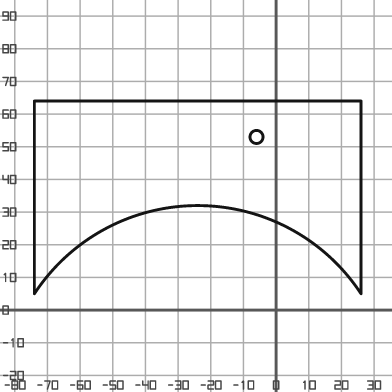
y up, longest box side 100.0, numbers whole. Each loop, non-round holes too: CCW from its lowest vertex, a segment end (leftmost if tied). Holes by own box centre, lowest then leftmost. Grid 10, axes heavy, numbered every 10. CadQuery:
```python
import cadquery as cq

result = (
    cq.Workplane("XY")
    .moveTo(-74.0, 5.0)
    .threePointArc((-24.0, 32.0), (26.0, 5.0))
    .lineTo(26.0, 64.0)
    .lineTo(-74.0, 64.0)
    .close()
    .moveTo(-6.0, 53.0)
    .circle(2.0)
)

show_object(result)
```